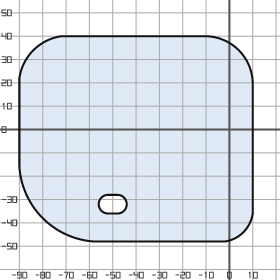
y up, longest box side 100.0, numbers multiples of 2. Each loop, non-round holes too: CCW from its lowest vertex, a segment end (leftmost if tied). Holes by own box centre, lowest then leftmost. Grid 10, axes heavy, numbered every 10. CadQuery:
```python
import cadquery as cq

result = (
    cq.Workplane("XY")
    .moveTo(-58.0, -48.0)
    .lineTo(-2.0, -48.0)
    .threePointArc((6.0, -44.0), (10.0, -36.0))
    .lineTo(10.0, 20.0)
    .threePointArc((4.0, 34.0), (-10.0, 40.0))
    .lineTo(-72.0, 40.0)
    .threePointArc((-84.0, 34.0), (-90.0, 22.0))
    .lineTo(-90.0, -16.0)
    .threePointArc((-80.0, -38.0), (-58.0, -48.0))
    .close()
    .moveTo(-52.0, -36.0)
    .lineTo(-48.0, -36.0)
    .threePointArc((-44.0, -32.0), (-48.0, -28.0))
    .lineTo(-52.0, -28.0)
    .threePointArc((-56.0, -32.0), (-52.0, -36.0))
    .close()
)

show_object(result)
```